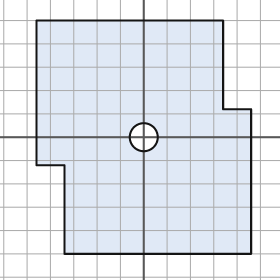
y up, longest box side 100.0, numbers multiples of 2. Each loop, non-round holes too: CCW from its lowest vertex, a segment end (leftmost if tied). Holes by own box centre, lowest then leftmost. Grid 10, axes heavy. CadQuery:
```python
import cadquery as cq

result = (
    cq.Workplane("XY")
    .moveTo(-34.0, -50.0)
    .lineTo(46.0, -50.0)
    .lineTo(46.0, 12.0)
    .lineTo(34.0, 12.0)
    .lineTo(34.0, 50.0)
    .lineTo(-46.0, 50.0)
    .lineTo(-46.0, -12.0)
    .lineTo(-34.0, -12.0)
    .close()
    .moveTo(0.0, 0.0)
    .circle(6.0)
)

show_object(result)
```